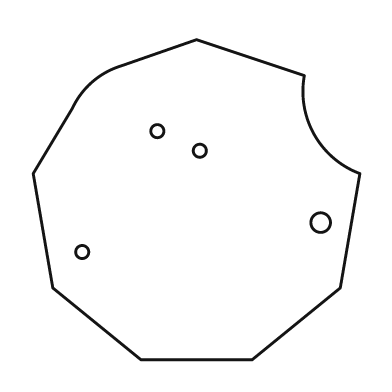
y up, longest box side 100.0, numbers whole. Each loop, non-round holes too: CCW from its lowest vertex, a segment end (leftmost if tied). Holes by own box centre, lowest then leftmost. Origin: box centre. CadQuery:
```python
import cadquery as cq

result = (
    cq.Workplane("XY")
    .moveTo(-17.0, -49.0)
    .lineTo(17.0, -49.0)
    .lineTo(44.0, -27.0)
    .lineTo(50.0, 8.0)
    .threePointArc((36.0, 20.0), (33.0, 38.0))
    .lineTo(0.0, 49.0)
    .lineTo(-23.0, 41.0)
    .threePointArc((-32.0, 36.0), (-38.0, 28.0))
    .lineTo(-50.0, 8.0)
    .lineTo(-44.0, -27.0)
    .close()
    .moveTo(-35.0, -16.0)
    .circle(2.0)
    .moveTo(38.0, -7.0)
    .circle(3.0)
    .moveTo(1.0, 15.0)
    .circle(2.0)
    .moveTo(-12.0, 21.0)
    .circle(2.0)
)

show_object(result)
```